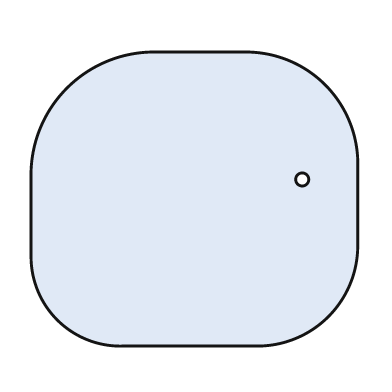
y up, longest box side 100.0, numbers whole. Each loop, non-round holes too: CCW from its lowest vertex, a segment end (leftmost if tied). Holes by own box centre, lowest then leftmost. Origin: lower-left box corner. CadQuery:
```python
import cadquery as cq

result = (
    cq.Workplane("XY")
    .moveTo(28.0, 0.0)
    .lineTo(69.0, 0.0)
    .threePointArc((91.0, 9.0), (100.0, 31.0))
    .lineTo(100.0, 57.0)
    .threePointArc((90.0, 80.0), (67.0, 90.0))
    .lineTo(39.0, 90.0)
    .threePointArc((11.0, 79.0), (0.0, 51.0))
    .lineTo(0.0, 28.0)
    .threePointArc((8.0, 8.0), (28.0, 0.0))
    .close()
    .moveTo(83.0, 51.0)
    .circle(2.0)
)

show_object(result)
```